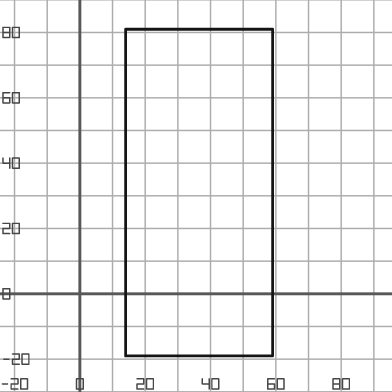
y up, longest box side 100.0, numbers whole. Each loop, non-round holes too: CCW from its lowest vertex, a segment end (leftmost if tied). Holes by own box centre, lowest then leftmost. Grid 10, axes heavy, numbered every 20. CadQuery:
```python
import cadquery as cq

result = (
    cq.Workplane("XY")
    .moveTo(14.0, -19.0)
    .lineTo(59.0, -19.0)
    .lineTo(59.0, 81.0)
    .lineTo(14.0, 81.0)
    .close()
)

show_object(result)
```